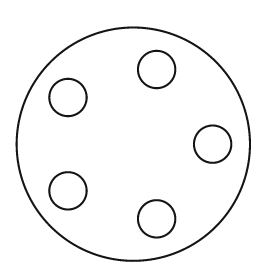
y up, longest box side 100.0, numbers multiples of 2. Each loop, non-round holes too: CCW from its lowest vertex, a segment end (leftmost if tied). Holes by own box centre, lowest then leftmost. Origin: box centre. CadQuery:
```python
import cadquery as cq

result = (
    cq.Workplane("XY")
    .moveTo(0.0, 0.0)
    .circle(50.0)
    .moveTo(10.0, -32.0)
    .circle(8.0)
    .moveTo(-28.0, -20.0)
    .circle(8.0)
    .moveTo(34.0, 0.0)
    .circle(8.0)
    .moveTo(-28.0, 20.0)
    .circle(8.0)
    .moveTo(10.0, 32.0)
    .circle(8.0)
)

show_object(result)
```